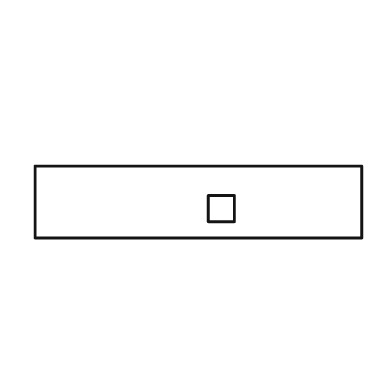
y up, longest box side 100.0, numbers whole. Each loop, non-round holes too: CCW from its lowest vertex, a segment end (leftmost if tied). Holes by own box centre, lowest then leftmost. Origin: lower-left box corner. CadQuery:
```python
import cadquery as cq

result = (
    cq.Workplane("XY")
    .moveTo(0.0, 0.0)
    .lineTo(100.0, 0.0)
    .lineTo(100.0, 22.0)
    .lineTo(0.0, 22.0)
    .close()
    .moveTo(53.0, 5.0)
    .lineTo(61.0, 5.0)
    .lineTo(61.0, 13.0)
    .lineTo(53.0, 13.0)
    .close()
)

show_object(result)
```